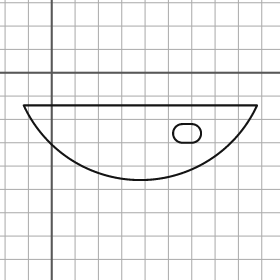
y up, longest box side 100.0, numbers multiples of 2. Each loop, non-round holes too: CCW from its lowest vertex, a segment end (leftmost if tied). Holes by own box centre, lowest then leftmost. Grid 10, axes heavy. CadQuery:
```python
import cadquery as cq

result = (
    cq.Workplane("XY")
    .moveTo(-12.0, -14.0)
    .threePointArc((38.0, -46.0), (88.0, -14.0))
    .close()
    .moveTo(56.0, -30.0)
    .lineTo(60.0, -30.0)
    .threePointArc((64.0, -26.0), (60.0, -22.0))
    .lineTo(56.0, -22.0)
    .threePointArc((52.0, -26.0), (56.0, -30.0))
    .close()
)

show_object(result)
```